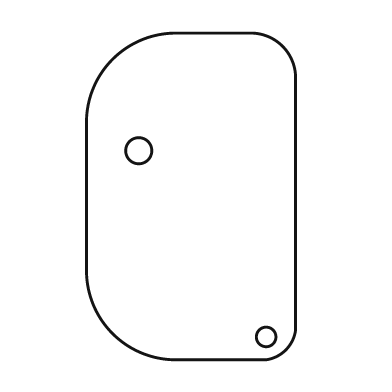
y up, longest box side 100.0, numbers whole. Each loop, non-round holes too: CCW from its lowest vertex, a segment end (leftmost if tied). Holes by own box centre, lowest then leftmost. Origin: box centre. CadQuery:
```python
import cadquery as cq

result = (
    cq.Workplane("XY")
    .moveTo(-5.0, -50.0)
    .lineTo(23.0, -50.0)
    .threePointArc((29.0, -47.0), (32.0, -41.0))
    .lineTo(32.0, 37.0)
    .threePointArc((28.0, 46.0), (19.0, 50.0))
    .lineTo(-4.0, 50.0)
    .threePointArc((-24.0, 42.0), (-32.0, 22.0))
    .lineTo(-32.0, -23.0)
    .threePointArc((-24.0, -42.0), (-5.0, -50.0))
    .close()
    .moveTo(23.0, -43.0)
    .circle(3.0)
    .moveTo(-16.0, 14.0)
    .circle(4.0)
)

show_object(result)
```